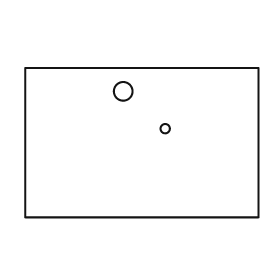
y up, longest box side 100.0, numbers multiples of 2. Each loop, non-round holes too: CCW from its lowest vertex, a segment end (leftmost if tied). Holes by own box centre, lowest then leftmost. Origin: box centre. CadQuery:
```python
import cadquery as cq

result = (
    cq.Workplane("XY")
    .moveTo(-50.0, -32.0)
    .lineTo(50.0, -32.0)
    .lineTo(50.0, 32.0)
    .lineTo(-50.0, 32.0)
    .close()
    .moveTo(10.0, 6.0)
    .circle(2.0)
    .moveTo(-8.0, 22.0)
    .circle(4.0)
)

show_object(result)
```